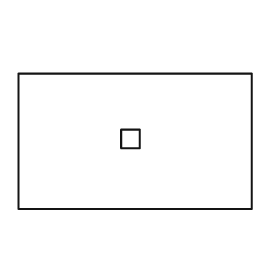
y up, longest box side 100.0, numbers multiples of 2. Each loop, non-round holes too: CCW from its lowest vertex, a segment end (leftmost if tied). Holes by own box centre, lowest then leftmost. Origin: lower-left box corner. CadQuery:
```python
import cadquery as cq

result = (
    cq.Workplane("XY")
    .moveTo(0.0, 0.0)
    .lineTo(100.0, 0.0)
    .lineTo(100.0, 58.0)
    .lineTo(0.0, 58.0)
    .close()
    .moveTo(44.0, 26.0)
    .lineTo(52.0, 26.0)
    .lineTo(52.0, 34.0)
    .lineTo(44.0, 34.0)
    .close()
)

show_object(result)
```